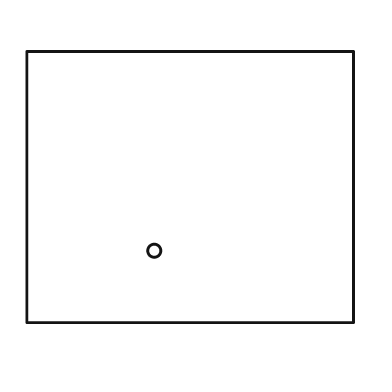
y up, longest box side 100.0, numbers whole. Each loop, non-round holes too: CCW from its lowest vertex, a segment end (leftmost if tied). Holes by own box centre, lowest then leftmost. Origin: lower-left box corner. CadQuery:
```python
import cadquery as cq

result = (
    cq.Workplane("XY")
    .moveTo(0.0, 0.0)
    .lineTo(100.0, 0.0)
    .lineTo(100.0, 83.0)
    .lineTo(0.0, 83.0)
    .close()
    .moveTo(39.0, 22.0)
    .circle(2.0)
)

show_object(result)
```